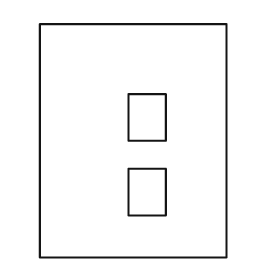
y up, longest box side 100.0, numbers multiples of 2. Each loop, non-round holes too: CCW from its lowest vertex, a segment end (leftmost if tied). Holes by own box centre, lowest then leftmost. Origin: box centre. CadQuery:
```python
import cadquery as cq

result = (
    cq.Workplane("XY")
    .moveTo(-40.0, -50.0)
    .lineTo(40.0, -50.0)
    .lineTo(40.0, 50.0)
    .lineTo(-40.0, 50.0)
    .close()
    .moveTo(-2.0, -32.0)
    .lineTo(14.0, -32.0)
    .lineTo(14.0, -12.0)
    .lineTo(-2.0, -12.0)
    .close()
    .moveTo(-2.0, 0.0)
    .lineTo(14.0, 0.0)
    .lineTo(14.0, 20.0)
    .lineTo(-2.0, 20.0)
    .close()
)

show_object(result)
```